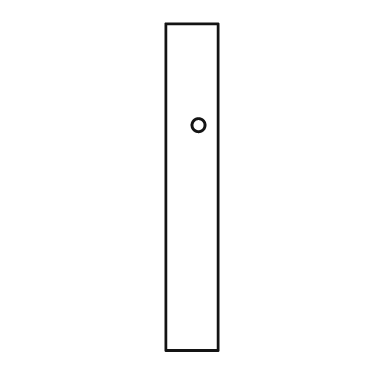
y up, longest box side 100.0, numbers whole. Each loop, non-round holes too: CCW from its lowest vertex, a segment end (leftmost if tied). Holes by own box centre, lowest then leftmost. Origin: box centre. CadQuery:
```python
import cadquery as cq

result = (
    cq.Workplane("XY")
    .moveTo(-8.0, -50.0)
    .lineTo(8.0, -50.0)
    .lineTo(8.0, 50.0)
    .lineTo(-8.0, 50.0)
    .close()
    .moveTo(2.0, 19.0)
    .circle(2.0)
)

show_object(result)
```